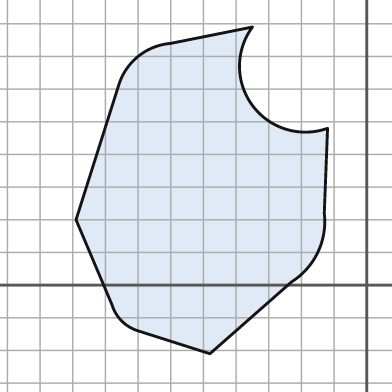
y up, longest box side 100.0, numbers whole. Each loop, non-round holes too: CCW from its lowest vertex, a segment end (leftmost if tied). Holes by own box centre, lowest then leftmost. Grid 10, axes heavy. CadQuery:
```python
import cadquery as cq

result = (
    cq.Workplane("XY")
    .moveTo(-48.0, -21.0)
    .lineTo(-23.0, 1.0)
    .threePointArc((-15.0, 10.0), (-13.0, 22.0))
    .lineTo(-12.0, 48.0)
    .threePointArc((-35.0, 55.0), (-35.0, 79.0))
    .lineTo(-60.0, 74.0)
    .threePointArc((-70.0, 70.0), (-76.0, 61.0))
    .lineTo(-89.0, 20.0)
    .lineTo(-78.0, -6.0)
    .threePointArc((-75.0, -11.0), (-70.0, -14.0))
    .close()
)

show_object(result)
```